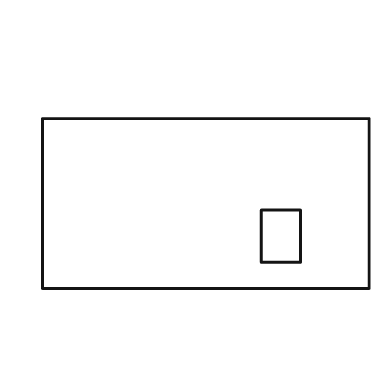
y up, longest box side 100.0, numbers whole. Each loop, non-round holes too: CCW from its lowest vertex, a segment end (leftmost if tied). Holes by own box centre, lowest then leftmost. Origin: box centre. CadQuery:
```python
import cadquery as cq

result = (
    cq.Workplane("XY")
    .moveTo(-50.0, -26.0)
    .lineTo(50.0, -26.0)
    .lineTo(50.0, 26.0)
    .lineTo(-50.0, 26.0)
    .close()
    .moveTo(17.0, -18.0)
    .lineTo(29.0, -18.0)
    .lineTo(29.0, -2.0)
    .lineTo(17.0, -2.0)
    .close()
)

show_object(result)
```